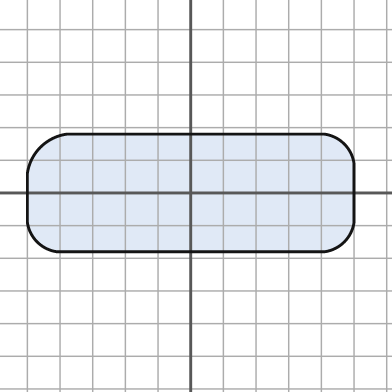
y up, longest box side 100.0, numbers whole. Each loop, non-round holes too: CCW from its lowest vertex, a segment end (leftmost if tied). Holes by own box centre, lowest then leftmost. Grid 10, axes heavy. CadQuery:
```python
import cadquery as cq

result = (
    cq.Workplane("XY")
    .moveTo(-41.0, -18.0)
    .lineTo(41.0, -18.0)
    .threePointArc((47.0, -15.0), (50.0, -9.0))
    .lineTo(50.0, 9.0)
    .threePointArc((47.0, 15.0), (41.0, 18.0))
    .lineTo(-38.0, 18.0)
    .threePointArc((-46.0, 14.0), (-50.0, 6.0))
    .lineTo(-50.0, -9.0)
    .threePointArc((-47.0, -15.0), (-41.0, -18.0))
    .close()
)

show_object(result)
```